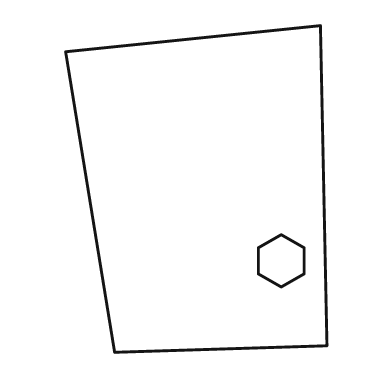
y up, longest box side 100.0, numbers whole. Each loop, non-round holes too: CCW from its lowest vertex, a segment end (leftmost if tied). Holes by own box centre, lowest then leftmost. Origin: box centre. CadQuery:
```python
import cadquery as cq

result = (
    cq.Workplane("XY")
    .moveTo(-25.0, -50.0)
    .lineTo(40.0, -48.0)
    .lineTo(38.0, 50.0)
    .lineTo(-40.0, 42.0)
    .close()
    .moveTo(26.0, -30.0)
    .lineTo(33.0, -26.0)
    .lineTo(33.0, -18.0)
    .lineTo(26.0, -14.0)
    .lineTo(19.0, -18.0)
    .lineTo(19.0, -26.0)
    .close()
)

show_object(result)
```